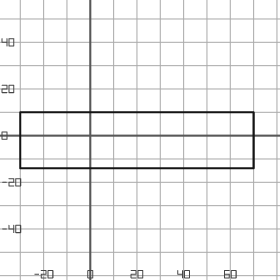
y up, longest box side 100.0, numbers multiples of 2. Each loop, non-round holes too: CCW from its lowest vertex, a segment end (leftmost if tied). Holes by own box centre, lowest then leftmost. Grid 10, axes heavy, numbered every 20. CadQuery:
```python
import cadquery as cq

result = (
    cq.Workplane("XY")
    .moveTo(-30.0, -14.0)
    .lineTo(70.0, -14.0)
    .lineTo(70.0, 10.0)
    .lineTo(-30.0, 10.0)
    .close()
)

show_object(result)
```